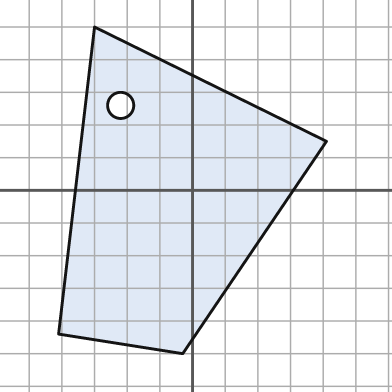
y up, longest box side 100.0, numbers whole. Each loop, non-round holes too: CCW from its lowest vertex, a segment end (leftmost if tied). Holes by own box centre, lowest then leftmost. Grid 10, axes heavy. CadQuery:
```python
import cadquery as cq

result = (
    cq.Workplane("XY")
    .moveTo(-3.0, -50.0)
    .lineTo(41.0, 15.0)
    .lineTo(-30.0, 50.0)
    .lineTo(-41.0, -44.0)
    .close()
    .moveTo(-22.0, 26.0)
    .circle(4.0)
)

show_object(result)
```